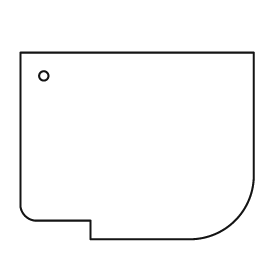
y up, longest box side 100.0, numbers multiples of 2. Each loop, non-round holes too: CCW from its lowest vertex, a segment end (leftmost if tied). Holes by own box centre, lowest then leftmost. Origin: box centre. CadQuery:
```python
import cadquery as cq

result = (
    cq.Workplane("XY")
    .moveTo(-20.0, -40.0)
    .lineTo(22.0, -40.0)
    .threePointArc((42.0, -32.0), (50.0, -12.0))
    .lineTo(50.0, 40.0)
    .lineTo(-50.0, 40.0)
    .lineTo(-50.0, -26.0)
    .threePointArc((-48.0, -30.0), (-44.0, -32.0))
    .lineTo(-20.0, -32.0)
    .close()
    .moveTo(-40.0, 30.0)
    .circle(2.0)
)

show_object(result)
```